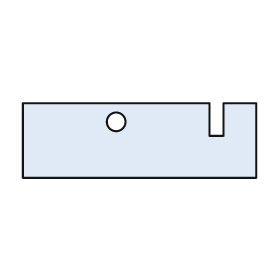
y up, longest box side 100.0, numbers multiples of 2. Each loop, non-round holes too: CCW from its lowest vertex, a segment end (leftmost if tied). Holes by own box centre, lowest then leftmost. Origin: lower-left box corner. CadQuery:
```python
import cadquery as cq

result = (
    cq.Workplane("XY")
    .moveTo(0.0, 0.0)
    .lineTo(100.0, 0.0)
    .lineTo(100.0, 32.0)
    .lineTo(86.0, 32.0)
    .lineTo(86.0, 18.0)
    .lineTo(80.0, 18.0)
    .lineTo(80.0, 32.0)
    .lineTo(0.0, 32.0)
    .close()
    .moveTo(40.0, 24.0)
    .circle(4.0)
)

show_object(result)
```